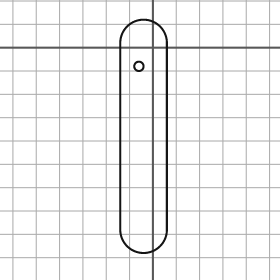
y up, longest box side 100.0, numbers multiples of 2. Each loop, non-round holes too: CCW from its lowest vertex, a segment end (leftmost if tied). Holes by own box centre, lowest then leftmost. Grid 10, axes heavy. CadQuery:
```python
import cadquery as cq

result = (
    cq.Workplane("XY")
    .moveTo(-14.0, -78.0)
    .threePointArc((-4.0, -88.0), (6.0, -78.0))
    .lineTo(6.0, 2.0)
    .threePointArc((-4.0, 12.0), (-14.0, 2.0))
    .close()
    .moveTo(-6.0, -8.0)
    .circle(2.0)
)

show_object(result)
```